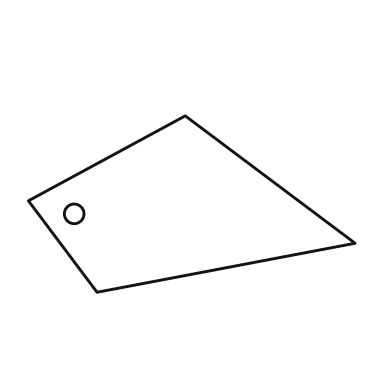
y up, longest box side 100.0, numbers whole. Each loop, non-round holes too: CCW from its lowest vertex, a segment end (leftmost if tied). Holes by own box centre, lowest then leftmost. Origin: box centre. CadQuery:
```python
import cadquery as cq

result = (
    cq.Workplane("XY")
    .moveTo(-29.0, -27.0)
    .lineTo(50.0, -12.0)
    .lineTo(-2.0, 27.0)
    .lineTo(-50.0, 1.0)
    .close()
    .moveTo(-36.0, -3.0)
    .circle(3.0)
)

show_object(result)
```